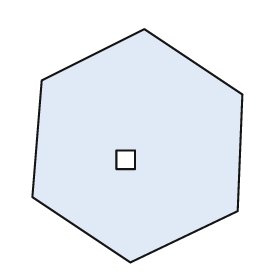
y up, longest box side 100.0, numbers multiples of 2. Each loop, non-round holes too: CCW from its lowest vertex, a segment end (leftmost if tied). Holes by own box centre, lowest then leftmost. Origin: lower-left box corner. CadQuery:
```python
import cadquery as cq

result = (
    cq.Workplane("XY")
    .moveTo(42.0, 0.0)
    .lineTo(88.0, 22.0)
    .lineTo(90.0, 72.0)
    .lineTo(48.0, 100.0)
    .lineTo(4.0, 78.0)
    .lineTo(0.0, 28.0)
    .close()
    .moveTo(36.0, 40.0)
    .lineTo(44.0, 40.0)
    .lineTo(44.0, 48.0)
    .lineTo(36.0, 48.0)
    .close()
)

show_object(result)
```